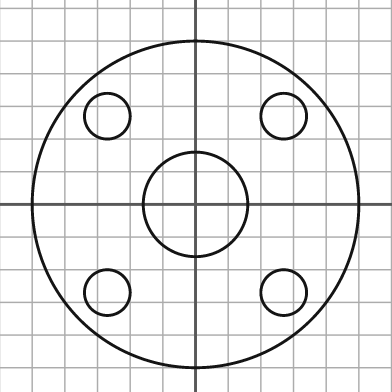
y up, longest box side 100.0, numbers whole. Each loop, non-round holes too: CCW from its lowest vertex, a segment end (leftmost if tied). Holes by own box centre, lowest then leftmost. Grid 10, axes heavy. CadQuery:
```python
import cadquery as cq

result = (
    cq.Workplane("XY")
    .moveTo(0.0, 0.0)
    .circle(50.0)
    .moveTo(-27.0, -27.0)
    .circle(7.0)
    .moveTo(27.0, -27.0)
    .circle(7.0)
    .moveTo(0.0, 0.0)
    .circle(16.0)
    .moveTo(-27.0, 27.0)
    .circle(7.0)
    .moveTo(27.0, 27.0)
    .circle(7.0)
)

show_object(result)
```